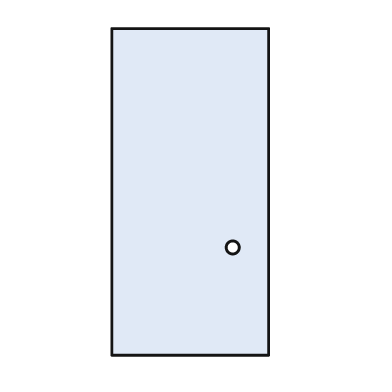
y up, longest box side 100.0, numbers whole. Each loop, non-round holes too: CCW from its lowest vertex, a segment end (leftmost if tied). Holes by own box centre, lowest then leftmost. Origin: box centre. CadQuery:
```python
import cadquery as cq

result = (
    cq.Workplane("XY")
    .moveTo(-24.0, -50.0)
    .lineTo(24.0, -50.0)
    .lineTo(24.0, 50.0)
    .lineTo(-24.0, 50.0)
    .close()
    .moveTo(13.0, -17.0)
    .circle(2.0)
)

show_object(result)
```